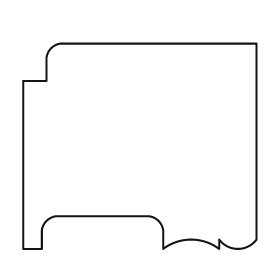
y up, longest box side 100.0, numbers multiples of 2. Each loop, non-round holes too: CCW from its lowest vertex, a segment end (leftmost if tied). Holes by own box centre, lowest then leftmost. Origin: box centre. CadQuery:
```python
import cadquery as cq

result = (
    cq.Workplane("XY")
    .moveTo(-50.0, -44.0)
    .lineTo(-42.0, -44.0)
    .lineTo(-42.0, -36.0)
    .threePointArc((-40.0, -32.0), (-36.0, -30.0))
    .lineTo(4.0, -30.0)
    .threePointArc((8.0, -32.0), (10.0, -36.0))
    .lineTo(10.0, -44.0)
    .threePointArc((22.0, -40.0), (34.0, -44.0))
    .lineTo(34.0, -40.0)
    .threePointArc((42.0, -44.0), (50.0, -40.0))
    .lineTo(50.0, 44.0)
    .lineTo(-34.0, 44.0)
    .threePointArc((-38.0, 42.0), (-40.0, 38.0))
    .lineTo(-40.0, 28.0)
    .lineTo(-50.0, 28.0)
    .close()
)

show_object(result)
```